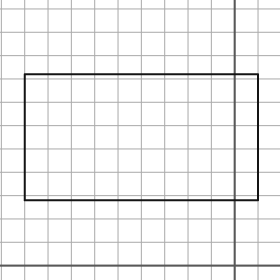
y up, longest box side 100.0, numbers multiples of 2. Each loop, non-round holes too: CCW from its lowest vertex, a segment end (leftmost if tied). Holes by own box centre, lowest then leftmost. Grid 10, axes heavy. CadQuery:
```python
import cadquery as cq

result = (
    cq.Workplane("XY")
    .moveTo(-90.0, 28.0)
    .lineTo(10.0, 28.0)
    .lineTo(10.0, 82.0)
    .lineTo(-90.0, 82.0)
    .close()
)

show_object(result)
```